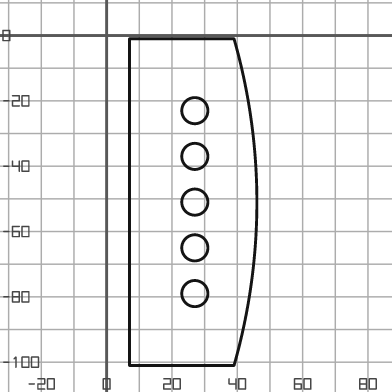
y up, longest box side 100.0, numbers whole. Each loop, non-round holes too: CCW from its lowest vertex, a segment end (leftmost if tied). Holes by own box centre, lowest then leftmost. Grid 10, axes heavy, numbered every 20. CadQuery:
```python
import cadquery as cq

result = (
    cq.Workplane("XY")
    .moveTo(7.0, -101.0)
    .lineTo(39.0, -101.0)
    .threePointArc((46.0, -51.0), (39.0, -1.0))
    .lineTo(7.0, -1.0)
    .close()
    .moveTo(27.0, -79.0)
    .circle(4.0)
    .moveTo(27.0, -65.0)
    .circle(4.0)
    .moveTo(27.0, -51.0)
    .circle(4.0)
    .moveTo(27.0, -37.0)
    .circle(4.0)
    .moveTo(27.0, -23.0)
    .circle(4.0)
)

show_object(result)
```